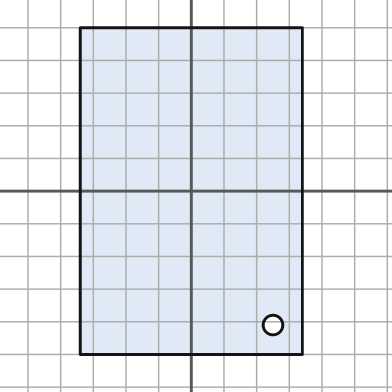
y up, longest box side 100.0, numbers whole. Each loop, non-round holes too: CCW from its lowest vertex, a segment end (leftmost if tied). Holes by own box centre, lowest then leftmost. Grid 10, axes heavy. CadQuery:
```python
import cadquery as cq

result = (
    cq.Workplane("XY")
    .moveTo(-34.0, -50.0)
    .lineTo(34.0, -50.0)
    .lineTo(34.0, 50.0)
    .lineTo(-34.0, 50.0)
    .close()
    .moveTo(25.0, -41.0)
    .circle(3.0)
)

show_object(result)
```